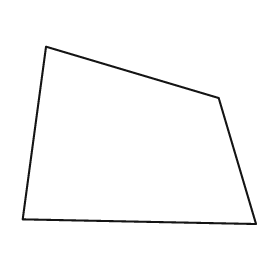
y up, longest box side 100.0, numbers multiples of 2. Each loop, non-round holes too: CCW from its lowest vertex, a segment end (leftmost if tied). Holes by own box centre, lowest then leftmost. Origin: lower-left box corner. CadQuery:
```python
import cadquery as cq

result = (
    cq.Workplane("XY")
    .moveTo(100.0, 0.0)
    .lineTo(84.0, 54.0)
    .lineTo(10.0, 76.0)
    .lineTo(0.0, 2.0)
    .close()
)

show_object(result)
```